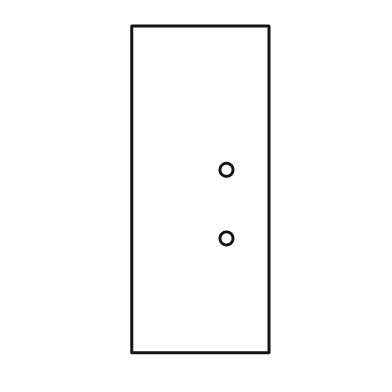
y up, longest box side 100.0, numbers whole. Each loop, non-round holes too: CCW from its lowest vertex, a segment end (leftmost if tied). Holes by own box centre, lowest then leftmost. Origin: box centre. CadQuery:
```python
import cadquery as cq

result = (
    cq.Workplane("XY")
    .moveTo(-21.0, -50.0)
    .lineTo(21.0, -50.0)
    .lineTo(21.0, 50.0)
    .lineTo(-21.0, 50.0)
    .close()
    .moveTo(8.0, -15.0)
    .circle(2.0)
    .moveTo(8.0, 6.0)
    .circle(2.0)
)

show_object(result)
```